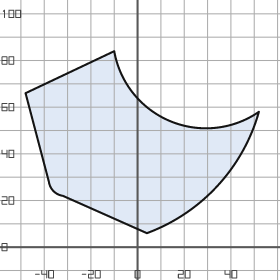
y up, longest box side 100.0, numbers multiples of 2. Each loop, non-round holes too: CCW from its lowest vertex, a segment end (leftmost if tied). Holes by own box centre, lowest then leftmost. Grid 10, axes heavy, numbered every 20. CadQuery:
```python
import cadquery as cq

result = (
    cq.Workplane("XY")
    .moveTo(4.0, 6.0)
    .threePointArc((34.0, 26.0), (52.0, 58.0))
    .threePointArc((14.0, 54.0), (-10.0, 84.0))
    .lineTo(-48.0, 66.0)
    .lineTo(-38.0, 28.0)
    .threePointArc((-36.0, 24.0), (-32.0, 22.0))
    .close()
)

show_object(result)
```